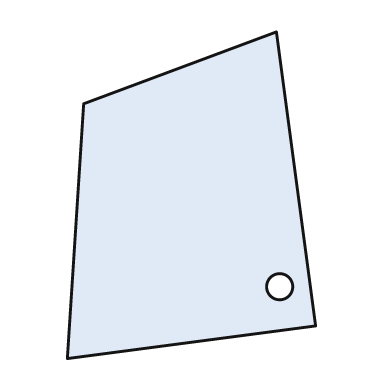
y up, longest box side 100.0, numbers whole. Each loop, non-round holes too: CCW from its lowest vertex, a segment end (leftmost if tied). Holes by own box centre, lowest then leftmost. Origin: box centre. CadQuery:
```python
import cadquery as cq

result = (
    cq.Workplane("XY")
    .moveTo(-38.0, -50.0)
    .lineTo(38.0, -40.0)
    .lineTo(26.0, 50.0)
    .lineTo(-33.0, 28.0)
    .close()
    .moveTo(27.0, -28.0)
    .circle(4.0)
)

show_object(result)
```